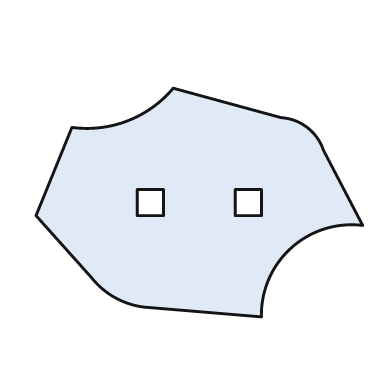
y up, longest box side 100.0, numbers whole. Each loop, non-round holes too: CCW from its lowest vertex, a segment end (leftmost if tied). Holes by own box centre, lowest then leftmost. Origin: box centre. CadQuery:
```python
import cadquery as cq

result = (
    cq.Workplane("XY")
    .moveTo(19.0, -35.0)
    .threePointArc((28.0, -14.0), (50.0, -7.0))
    .lineTo(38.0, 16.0)
    .threePointArc((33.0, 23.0), (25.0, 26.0))
    .lineTo(-8.0, 35.0)
    .threePointArc((-22.0, 25.0), (-39.0, 23.0))
    .lineTo(-50.0, -4.0)
    .lineTo(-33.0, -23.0)
    .threePointArc((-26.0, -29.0), (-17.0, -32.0))
    .close()
    .moveTo(-19.0, -4.0)
    .lineTo(-11.0, -4.0)
    .lineTo(-11.0, 4.0)
    .lineTo(-19.0, 4.0)
    .close()
    .moveTo(11.0, -4.0)
    .lineTo(19.0, -4.0)
    .lineTo(19.0, 4.0)
    .lineTo(11.0, 4.0)
    .close()
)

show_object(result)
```